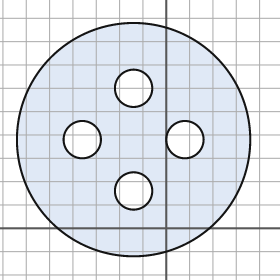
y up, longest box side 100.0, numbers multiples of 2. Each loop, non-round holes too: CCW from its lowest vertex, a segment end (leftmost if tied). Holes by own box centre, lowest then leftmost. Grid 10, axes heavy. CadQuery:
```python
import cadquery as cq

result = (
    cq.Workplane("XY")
    .moveTo(-14.0, 38.0)
    .circle(50.0)
    .moveTo(-14.0, 16.0)
    .circle(8.0)
    .moveTo(-36.0, 38.0)
    .circle(8.0)
    .moveTo(8.0, 38.0)
    .circle(8.0)
    .moveTo(-14.0, 60.0)
    .circle(8.0)
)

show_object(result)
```